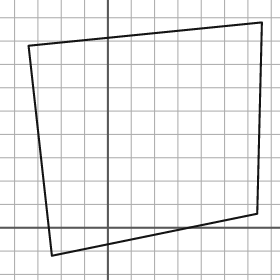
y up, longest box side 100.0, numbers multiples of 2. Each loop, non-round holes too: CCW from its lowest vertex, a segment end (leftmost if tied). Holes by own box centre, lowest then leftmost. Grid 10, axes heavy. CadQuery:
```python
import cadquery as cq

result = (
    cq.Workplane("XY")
    .moveTo(-24.0, -12.0)
    .lineTo(64.0, 6.0)
    .lineTo(66.0, 88.0)
    .lineTo(-34.0, 78.0)
    .close()
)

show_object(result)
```